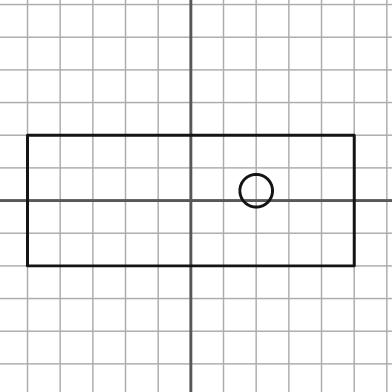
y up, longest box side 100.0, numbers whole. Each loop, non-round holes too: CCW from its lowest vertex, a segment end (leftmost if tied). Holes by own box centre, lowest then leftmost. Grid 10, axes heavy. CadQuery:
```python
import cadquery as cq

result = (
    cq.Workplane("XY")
    .moveTo(-50.0, -20.0)
    .lineTo(50.0, -20.0)
    .lineTo(50.0, 20.0)
    .lineTo(-50.0, 20.0)
    .close()
    .moveTo(20.0, 3.0)
    .circle(5.0)
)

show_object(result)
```